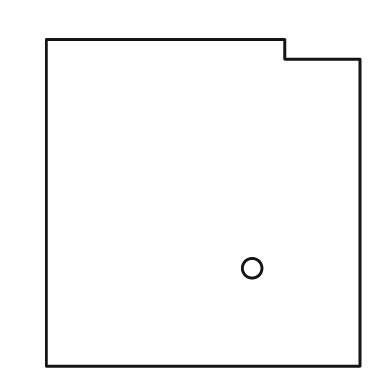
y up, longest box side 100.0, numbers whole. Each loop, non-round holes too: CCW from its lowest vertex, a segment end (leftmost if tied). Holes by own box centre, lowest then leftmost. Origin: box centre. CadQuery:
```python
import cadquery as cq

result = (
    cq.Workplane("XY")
    .moveTo(-48.0, -50.0)
    .lineTo(48.0, -50.0)
    .lineTo(48.0, 44.0)
    .lineTo(25.0, 44.0)
    .lineTo(25.0, 50.0)
    .lineTo(-48.0, 50.0)
    .close()
    .moveTo(15.0, -20.0)
    .circle(3.0)
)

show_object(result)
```